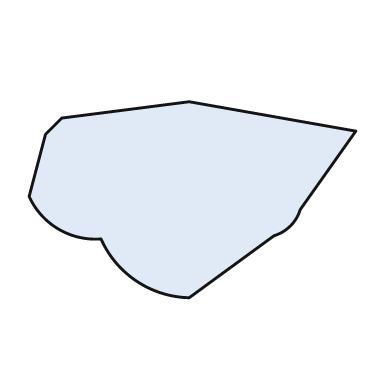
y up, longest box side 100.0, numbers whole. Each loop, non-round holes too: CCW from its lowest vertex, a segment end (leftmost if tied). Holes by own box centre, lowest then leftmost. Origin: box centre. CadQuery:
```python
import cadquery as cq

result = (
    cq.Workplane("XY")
    .moveTo(-1.0, -30.0)
    .lineTo(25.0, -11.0)
    .threePointArc((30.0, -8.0), (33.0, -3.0))
    .lineTo(50.0, 21.0)
    .lineTo(-1.0, 30.0)
    .lineTo(-40.0, 25.0)
    .lineTo(-45.0, 20.0)
    .lineTo(-50.0, 1.0)
    .threePointArc((-41.0, -9.0), (-28.0, -12.0))
    .threePointArc((-17.0, -25.0), (-1.0, -30.0))
    .close()
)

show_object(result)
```